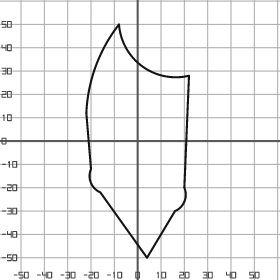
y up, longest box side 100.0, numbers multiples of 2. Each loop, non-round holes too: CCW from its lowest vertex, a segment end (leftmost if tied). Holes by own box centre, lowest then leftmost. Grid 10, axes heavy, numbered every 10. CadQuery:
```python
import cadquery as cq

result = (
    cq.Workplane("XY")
    .moveTo(4.0, -50.0)
    .lineTo(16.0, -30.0)
    .threePointArc((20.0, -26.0), (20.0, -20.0))
    .lineTo(22.0, 28.0)
    .threePointArc((2.0, 32.0), (-8.0, 50.0))
    .threePointArc((-18.0, 32.0), (-22.0, 12.0))
    .lineTo(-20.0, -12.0)
    .threePointArc((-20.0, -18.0), (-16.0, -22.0))
    .close()
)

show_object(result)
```